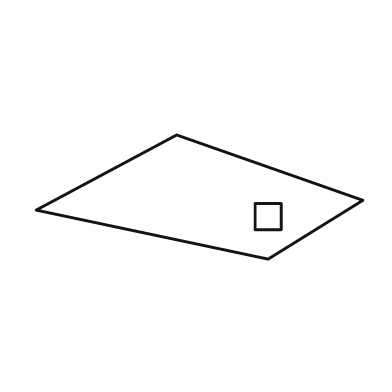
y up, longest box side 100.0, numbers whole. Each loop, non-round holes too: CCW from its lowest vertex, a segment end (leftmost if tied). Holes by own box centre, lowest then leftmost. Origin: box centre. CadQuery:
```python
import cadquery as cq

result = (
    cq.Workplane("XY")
    .moveTo(21.0, -19.0)
    .lineTo(50.0, -1.0)
    .lineTo(-7.0, 19.0)
    .lineTo(-50.0, -4.0)
    .close()
    .moveTo(17.0, -10.0)
    .lineTo(25.0, -10.0)
    .lineTo(25.0, -2.0)
    .lineTo(17.0, -2.0)
    .close()
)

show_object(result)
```